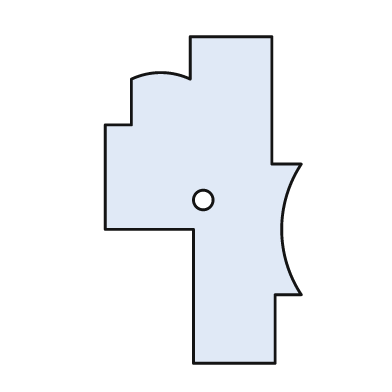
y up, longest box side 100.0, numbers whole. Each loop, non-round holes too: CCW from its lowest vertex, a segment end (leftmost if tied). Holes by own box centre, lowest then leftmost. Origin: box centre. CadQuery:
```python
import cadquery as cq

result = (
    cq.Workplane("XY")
    .moveTo(-3.0, -50.0)
    .lineTo(22.0, -50.0)
    .lineTo(22.0, -29.0)
    .lineTo(30.0, -29.0)
    .threePointArc((24.0, -9.0), (30.0, 11.0))
    .lineTo(21.0, 11.0)
    .lineTo(21.0, 50.0)
    .lineTo(-4.0, 50.0)
    .lineTo(-4.0, 37.0)
    .threePointArc((-13.0, 39.0), (-22.0, 37.0))
    .lineTo(-22.0, 23.0)
    .lineTo(-30.0, 23.0)
    .lineTo(-30.0, -9.0)
    .lineTo(-3.0, -9.0)
    .close()
    .moveTo(0.0, 0.0)
    .circle(3.0)
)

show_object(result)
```